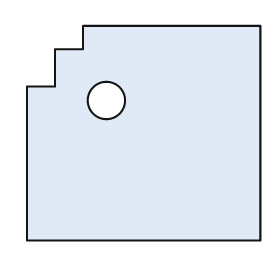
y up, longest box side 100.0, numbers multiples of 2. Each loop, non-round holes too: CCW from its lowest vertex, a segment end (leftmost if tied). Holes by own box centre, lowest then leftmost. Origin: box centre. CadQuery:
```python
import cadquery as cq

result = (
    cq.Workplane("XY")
    .moveTo(-50.0, -46.0)
    .lineTo(50.0, -46.0)
    .lineTo(50.0, 46.0)
    .lineTo(-26.0, 46.0)
    .lineTo(-26.0, 36.0)
    .lineTo(-38.0, 36.0)
    .lineTo(-38.0, 20.0)
    .lineTo(-50.0, 20.0)
    .close()
    .moveTo(-16.0, 14.0)
    .circle(8.0)
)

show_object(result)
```